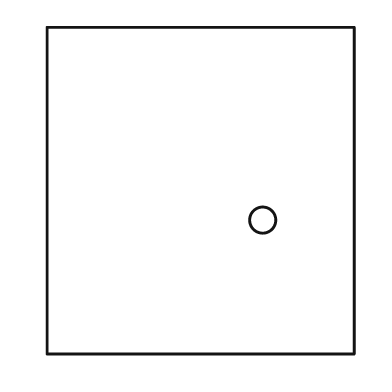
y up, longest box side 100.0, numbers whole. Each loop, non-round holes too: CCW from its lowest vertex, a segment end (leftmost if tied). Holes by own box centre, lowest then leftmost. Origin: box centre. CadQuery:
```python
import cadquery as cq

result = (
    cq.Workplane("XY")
    .moveTo(-47.0, -50.0)
    .lineTo(47.0, -50.0)
    .lineTo(47.0, 50.0)
    .lineTo(-47.0, 50.0)
    .close()
    .moveTo(19.0, -9.0)
    .circle(4.0)
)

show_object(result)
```